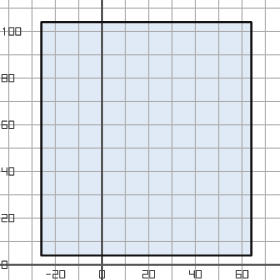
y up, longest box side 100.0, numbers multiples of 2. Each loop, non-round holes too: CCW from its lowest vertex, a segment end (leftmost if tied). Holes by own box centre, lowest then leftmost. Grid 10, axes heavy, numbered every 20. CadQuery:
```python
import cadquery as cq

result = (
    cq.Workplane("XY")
    .moveTo(-26.0, 4.0)
    .lineTo(64.0, 4.0)
    .lineTo(64.0, 104.0)
    .lineTo(-26.0, 104.0)
    .close()
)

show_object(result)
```